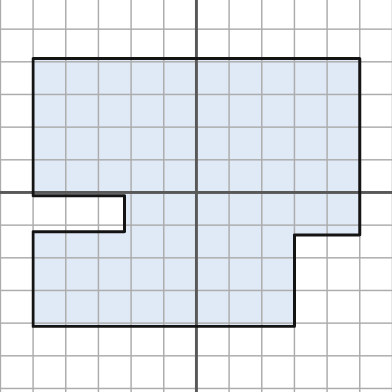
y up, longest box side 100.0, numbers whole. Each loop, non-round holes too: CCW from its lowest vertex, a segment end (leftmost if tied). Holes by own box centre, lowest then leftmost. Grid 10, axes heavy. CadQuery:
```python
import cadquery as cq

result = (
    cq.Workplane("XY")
    .moveTo(-50.0, -41.0)
    .lineTo(30.0, -41.0)
    .lineTo(30.0, -13.0)
    .lineTo(50.0, -13.0)
    .lineTo(50.0, 41.0)
    .lineTo(-50.0, 41.0)
    .lineTo(-50.0, -1.0)
    .lineTo(-22.0, -1.0)
    .lineTo(-22.0, -12.0)
    .lineTo(-50.0, -12.0)
    .close()
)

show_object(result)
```